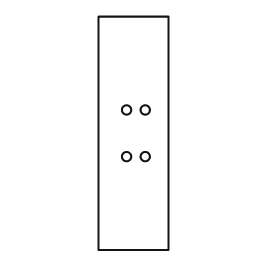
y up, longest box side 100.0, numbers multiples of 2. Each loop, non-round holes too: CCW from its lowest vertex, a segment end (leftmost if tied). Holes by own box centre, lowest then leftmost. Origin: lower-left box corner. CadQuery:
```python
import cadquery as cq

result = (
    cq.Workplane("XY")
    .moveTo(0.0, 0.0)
    .lineTo(30.0, 0.0)
    .lineTo(30.0, 100.0)
    .lineTo(0.0, 100.0)
    .close()
    .moveTo(12.0, 40.0)
    .circle(2.0)
    .moveTo(20.0, 40.0)
    .circle(2.0)
    .moveTo(12.0, 60.0)
    .circle(2.0)
    .moveTo(20.0, 60.0)
    .circle(2.0)
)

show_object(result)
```